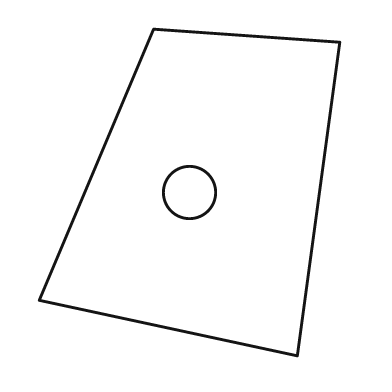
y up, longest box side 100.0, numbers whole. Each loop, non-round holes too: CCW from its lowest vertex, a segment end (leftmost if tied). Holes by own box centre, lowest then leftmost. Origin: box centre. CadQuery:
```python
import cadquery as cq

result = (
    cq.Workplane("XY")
    .moveTo(33.0, -50.0)
    .lineTo(46.0, 46.0)
    .lineTo(-11.0, 50.0)
    .lineTo(-46.0, -33.0)
    .close()
    .moveTo(0.0, 0.0)
    .circle(8.0)
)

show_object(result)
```